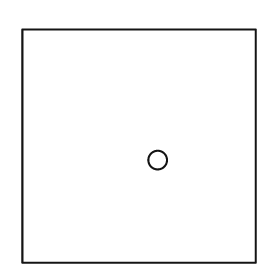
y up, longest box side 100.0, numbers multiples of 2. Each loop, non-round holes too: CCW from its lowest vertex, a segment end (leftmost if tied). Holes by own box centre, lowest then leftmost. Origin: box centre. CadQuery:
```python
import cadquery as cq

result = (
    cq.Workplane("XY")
    .moveTo(-50.0, -50.0)
    .lineTo(50.0, -50.0)
    .lineTo(50.0, 50.0)
    .lineTo(-50.0, 50.0)
    .close()
    .moveTo(8.0, -6.0)
    .circle(4.0)
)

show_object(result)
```